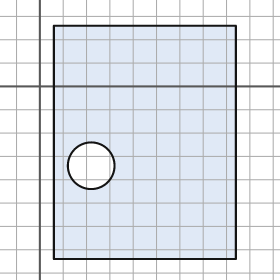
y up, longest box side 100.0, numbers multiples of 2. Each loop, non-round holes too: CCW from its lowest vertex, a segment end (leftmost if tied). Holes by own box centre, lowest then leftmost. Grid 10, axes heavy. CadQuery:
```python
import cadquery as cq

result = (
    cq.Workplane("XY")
    .moveTo(6.0, -74.0)
    .lineTo(84.0, -74.0)
    .lineTo(84.0, 26.0)
    .lineTo(6.0, 26.0)
    .close()
    .moveTo(22.0, -34.0)
    .circle(10.0)
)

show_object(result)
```